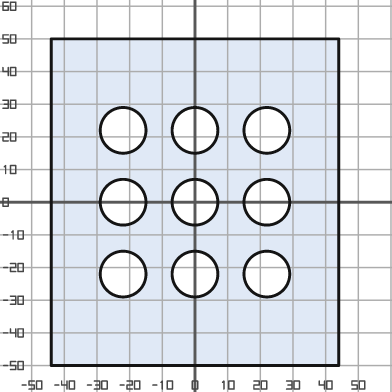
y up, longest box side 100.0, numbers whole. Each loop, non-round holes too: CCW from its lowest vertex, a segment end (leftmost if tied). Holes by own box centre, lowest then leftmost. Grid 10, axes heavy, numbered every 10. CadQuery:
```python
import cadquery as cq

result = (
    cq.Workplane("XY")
    .moveTo(-44.0, -50.0)
    .lineTo(44.0, -50.0)
    .lineTo(44.0, 50.0)
    .lineTo(-44.0, 50.0)
    .close()
    .moveTo(-22.0, -22.0)
    .circle(7.0)
    .moveTo(0.0, -22.0)
    .circle(7.0)
    .moveTo(22.0, -22.0)
    .circle(7.0)
    .moveTo(-22.0, 0.0)
    .circle(7.0)
    .moveTo(0.0, 0.0)
    .circle(7.0)
    .moveTo(22.0, 0.0)
    .circle(7.0)
    .moveTo(-22.0, 22.0)
    .circle(7.0)
    .moveTo(0.0, 22.0)
    .circle(7.0)
    .moveTo(22.0, 22.0)
    .circle(7.0)
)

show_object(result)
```